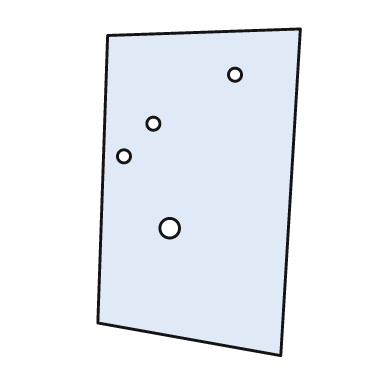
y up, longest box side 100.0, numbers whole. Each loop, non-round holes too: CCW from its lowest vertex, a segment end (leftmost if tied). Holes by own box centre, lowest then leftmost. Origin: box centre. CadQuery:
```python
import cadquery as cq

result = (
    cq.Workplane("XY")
    .moveTo(25.0, -50.0)
    .lineTo(31.0, 50.0)
    .lineTo(-28.0, 48.0)
    .lineTo(-31.0, -40.0)
    .close()
    .moveTo(-9.0, -11.0)
    .circle(3.0)
    .moveTo(-23.0, 11.0)
    .circle(2.0)
    .moveTo(-14.0, 21.0)
    .circle(2.0)
    .moveTo(11.0, 36.0)
    .circle(2.0)
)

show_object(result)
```